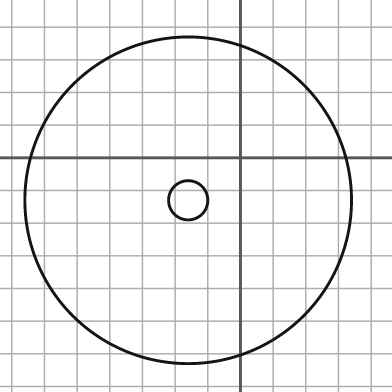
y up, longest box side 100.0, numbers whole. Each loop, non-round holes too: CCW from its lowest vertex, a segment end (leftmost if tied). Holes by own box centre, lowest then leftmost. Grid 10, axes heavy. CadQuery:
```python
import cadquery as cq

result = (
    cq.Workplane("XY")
    .moveTo(-16.0, -13.0)
    .circle(50.0)
    .moveTo(-16.0, -13.0)
    .circle(6.0)
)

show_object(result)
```